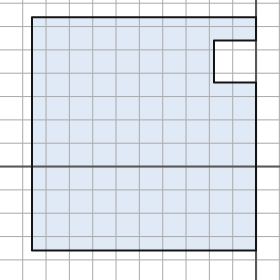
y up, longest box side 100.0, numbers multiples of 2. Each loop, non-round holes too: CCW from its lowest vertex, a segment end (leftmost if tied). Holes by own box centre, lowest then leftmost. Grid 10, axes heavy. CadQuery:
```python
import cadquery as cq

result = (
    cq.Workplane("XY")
    .moveTo(-96.0, -36.0)
    .lineTo(0.0, -36.0)
    .lineTo(0.0, 36.0)
    .lineTo(-18.0, 36.0)
    .lineTo(-18.0, 54.0)
    .lineTo(0.0, 54.0)
    .lineTo(0.0, 64.0)
    .lineTo(-96.0, 64.0)
    .close()
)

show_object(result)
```